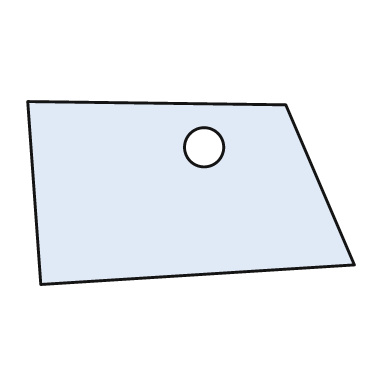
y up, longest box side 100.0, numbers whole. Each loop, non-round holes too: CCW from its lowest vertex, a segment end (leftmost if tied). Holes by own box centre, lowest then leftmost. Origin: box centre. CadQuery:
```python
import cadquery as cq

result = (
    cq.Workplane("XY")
    .moveTo(-46.0, -28.0)
    .lineTo(50.0, -22.0)
    .lineTo(29.0, 27.0)
    .lineTo(-50.0, 28.0)
    .close()
    .moveTo(4.0, 14.0)
    .circle(6.0)
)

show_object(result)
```